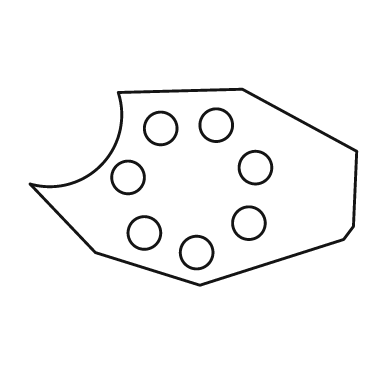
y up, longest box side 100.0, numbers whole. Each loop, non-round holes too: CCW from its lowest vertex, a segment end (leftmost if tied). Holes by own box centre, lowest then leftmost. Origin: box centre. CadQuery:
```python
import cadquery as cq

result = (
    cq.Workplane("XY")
    .moveTo(2.0, -30.0)
    .lineTo(46.0, -16.0)
    .lineTo(49.0, -12.0)
    .lineTo(50.0, 11.0)
    .lineTo(15.0, 30.0)
    .lineTo(-23.0, 29.0)
    .threePointArc((-28.0, 7.0), (-50.0, 1.0))
    .lineTo(-30.0, -20.0)
    .close()
    .moveTo(1.0, -20.0)
    .circle(5.0)
    .moveTo(-15.0, -14.0)
    .circle(5.0)
    .moveTo(17.0, -11.0)
    .circle(5.0)
    .moveTo(-20.0, 3.0)
    .circle(5.0)
    .moveTo(19.0, 6.0)
    .circle(5.0)
    .moveTo(-10.0, 18.0)
    .circle(5.0)
    .moveTo(7.0, 19.0)
    .circle(5.0)
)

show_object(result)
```